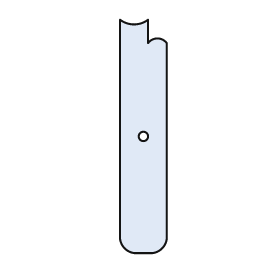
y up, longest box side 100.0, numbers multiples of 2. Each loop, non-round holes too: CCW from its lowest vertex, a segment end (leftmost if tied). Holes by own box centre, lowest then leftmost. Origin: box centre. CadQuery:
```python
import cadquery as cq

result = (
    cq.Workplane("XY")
    .moveTo(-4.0, -50.0)
    .lineTo(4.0, -50.0)
    .threePointArc((8.0, -48.0), (10.0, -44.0))
    .lineTo(10.0, 40.0)
    .threePointArc((6.0, 42.0), (2.0, 40.0))
    .lineTo(2.0, 50.0)
    .threePointArc((-4.0, 48.0), (-10.0, 50.0))
    .lineTo(-10.0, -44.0)
    .threePointArc((-8.0, -48.0), (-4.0, -50.0))
    .close()
    .moveTo(0.0, 0.0)
    .circle(2.0)
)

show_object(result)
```